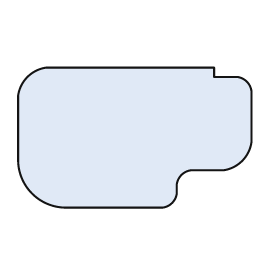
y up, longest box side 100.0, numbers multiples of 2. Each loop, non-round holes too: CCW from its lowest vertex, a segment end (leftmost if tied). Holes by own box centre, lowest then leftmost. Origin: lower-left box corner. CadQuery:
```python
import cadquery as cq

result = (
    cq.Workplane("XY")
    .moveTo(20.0, 0.0)
    .lineTo(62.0, 0.0)
    .threePointArc((66.0, 2.0), (68.0, 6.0))
    .lineTo(68.0, 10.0)
    .threePointArc((70.0, 14.0), (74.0, 16.0))
    .lineTo(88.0, 16.0)
    .threePointArc((96.0, 20.0), (100.0, 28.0))
    .lineTo(100.0, 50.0)
    .threePointArc((98.0, 54.0), (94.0, 56.0))
    .lineTo(84.0, 56.0)
    .lineTo(84.0, 60.0)
    .lineTo(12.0, 60.0)
    .threePointArc((4.0, 56.0), (0.0, 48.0))
    .lineTo(0.0, 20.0)
    .threePointArc((6.0, 6.0), (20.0, 0.0))
    .close()
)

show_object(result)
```